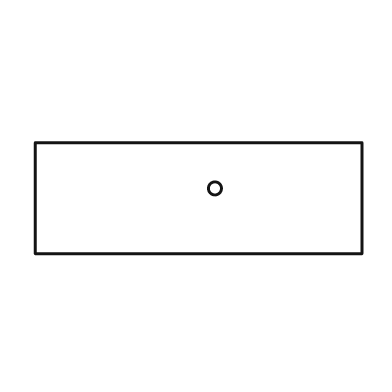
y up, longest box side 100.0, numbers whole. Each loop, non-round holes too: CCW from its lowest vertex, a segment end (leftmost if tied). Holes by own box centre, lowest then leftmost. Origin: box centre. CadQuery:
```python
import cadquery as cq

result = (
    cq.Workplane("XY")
    .moveTo(-50.0, -17.0)
    .lineTo(50.0, -17.0)
    .lineTo(50.0, 17.0)
    .lineTo(-50.0, 17.0)
    .close()
    .moveTo(5.0, 3.0)
    .circle(2.0)
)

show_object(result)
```